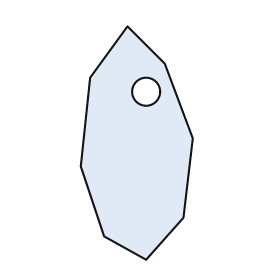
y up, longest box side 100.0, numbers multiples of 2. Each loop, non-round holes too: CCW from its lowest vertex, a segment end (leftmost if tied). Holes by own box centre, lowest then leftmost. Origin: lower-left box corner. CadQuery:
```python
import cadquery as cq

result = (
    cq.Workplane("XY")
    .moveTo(28.0, 0.0)
    .lineTo(44.0, 18.0)
    .lineTo(48.0, 52.0)
    .lineTo(36.0, 84.0)
    .lineTo(20.0, 100.0)
    .lineTo(4.0, 78.0)
    .lineTo(0.0, 40.0)
    .lineTo(10.0, 10.0)
    .close()
    .moveTo(28.0, 72.0)
    .circle(6.0)
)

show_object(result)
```